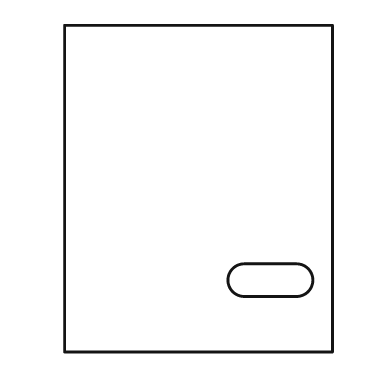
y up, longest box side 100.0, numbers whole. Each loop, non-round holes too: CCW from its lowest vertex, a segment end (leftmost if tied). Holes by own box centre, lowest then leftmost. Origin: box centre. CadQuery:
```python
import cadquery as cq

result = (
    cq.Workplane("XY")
    .moveTo(-41.0, -50.0)
    .lineTo(41.0, -50.0)
    .lineTo(41.0, 50.0)
    .lineTo(-41.0, 50.0)
    .close()
    .moveTo(14.0, -33.0)
    .lineTo(30.0, -33.0)
    .threePointArc((35.0, -28.0), (30.0, -23.0))
    .lineTo(14.0, -23.0)
    .threePointArc((9.0, -28.0), (14.0, -33.0))
    .close()
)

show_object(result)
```